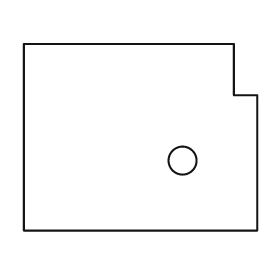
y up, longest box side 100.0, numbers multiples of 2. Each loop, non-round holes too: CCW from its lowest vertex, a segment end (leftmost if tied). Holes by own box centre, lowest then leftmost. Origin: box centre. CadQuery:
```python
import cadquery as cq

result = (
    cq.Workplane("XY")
    .moveTo(-50.0, -40.0)
    .lineTo(50.0, -40.0)
    .lineTo(50.0, 18.0)
    .lineTo(40.0, 18.0)
    .lineTo(40.0, 40.0)
    .lineTo(-50.0, 40.0)
    .close()
    .moveTo(18.0, -10.0)
    .circle(6.0)
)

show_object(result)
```